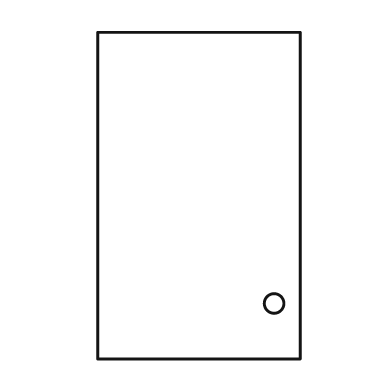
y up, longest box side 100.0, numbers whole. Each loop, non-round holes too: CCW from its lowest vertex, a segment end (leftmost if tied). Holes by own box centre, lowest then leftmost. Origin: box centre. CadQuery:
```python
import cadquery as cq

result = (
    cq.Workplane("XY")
    .moveTo(-31.0, -50.0)
    .lineTo(31.0, -50.0)
    .lineTo(31.0, 50.0)
    .lineTo(-31.0, 50.0)
    .close()
    .moveTo(23.0, -33.0)
    .circle(3.0)
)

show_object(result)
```